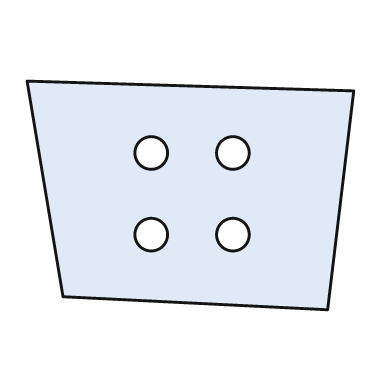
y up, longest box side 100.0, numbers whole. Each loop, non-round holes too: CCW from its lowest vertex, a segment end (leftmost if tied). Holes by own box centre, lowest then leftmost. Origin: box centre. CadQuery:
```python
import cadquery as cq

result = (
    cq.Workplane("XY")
    .moveTo(42.0, -35.0)
    .lineTo(50.0, 32.0)
    .lineTo(-50.0, 35.0)
    .lineTo(-39.0, -31.0)
    .close()
    .moveTo(-12.0, -12.0)
    .circle(5.0)
    .moveTo(13.0, -12.0)
    .circle(5.0)
    .moveTo(-12.0, 13.0)
    .circle(5.0)
    .moveTo(13.0, 13.0)
    .circle(5.0)
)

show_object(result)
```